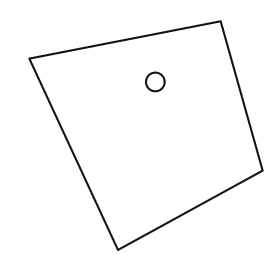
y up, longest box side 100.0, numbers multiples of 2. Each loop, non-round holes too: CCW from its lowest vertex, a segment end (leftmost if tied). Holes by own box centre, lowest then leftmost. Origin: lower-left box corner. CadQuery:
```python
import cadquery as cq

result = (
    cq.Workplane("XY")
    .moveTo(38.0, 0.0)
    .lineTo(100.0, 34.0)
    .lineTo(82.0, 98.0)
    .lineTo(0.0, 82.0)
    .close()
    .moveTo(54.0, 72.0)
    .circle(4.0)
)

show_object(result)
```